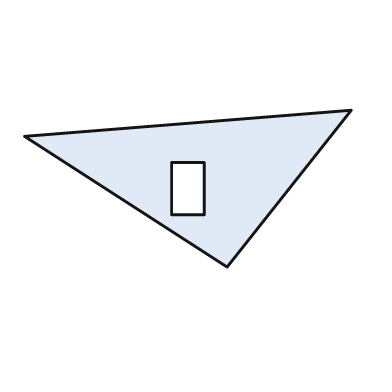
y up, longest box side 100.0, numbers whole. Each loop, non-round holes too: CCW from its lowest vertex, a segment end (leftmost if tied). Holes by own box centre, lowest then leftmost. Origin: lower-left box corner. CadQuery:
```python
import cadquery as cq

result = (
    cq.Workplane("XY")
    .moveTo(62.0, 0.0)
    .lineTo(100.0, 48.0)
    .lineTo(0.0, 40.0)
    .close()
    .moveTo(45.0, 16.0)
    .lineTo(55.0, 16.0)
    .lineTo(55.0, 32.0)
    .lineTo(45.0, 32.0)
    .close()
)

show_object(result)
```